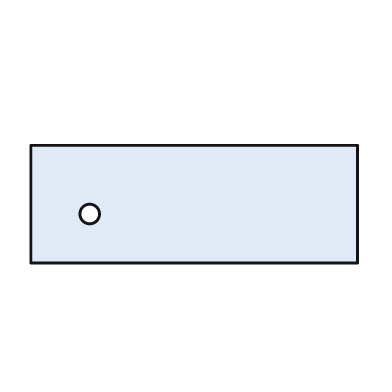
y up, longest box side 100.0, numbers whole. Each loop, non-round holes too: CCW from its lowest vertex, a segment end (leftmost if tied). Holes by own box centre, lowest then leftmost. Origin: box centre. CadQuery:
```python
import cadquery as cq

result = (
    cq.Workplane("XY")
    .moveTo(-50.0, -18.0)
    .lineTo(50.0, -18.0)
    .lineTo(50.0, 18.0)
    .lineTo(-50.0, 18.0)
    .close()
    .moveTo(-32.0, -3.0)
    .circle(3.0)
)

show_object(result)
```